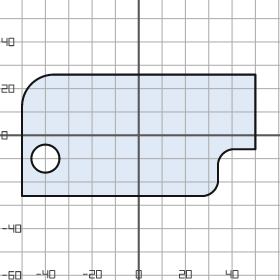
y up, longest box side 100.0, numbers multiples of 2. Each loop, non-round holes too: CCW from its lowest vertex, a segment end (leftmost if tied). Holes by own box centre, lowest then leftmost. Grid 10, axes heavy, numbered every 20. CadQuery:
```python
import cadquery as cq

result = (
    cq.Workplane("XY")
    .moveTo(-50.0, -26.0)
    .lineTo(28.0, -26.0)
    .threePointArc((32.0, -24.0), (34.0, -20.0))
    .lineTo(34.0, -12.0)
    .threePointArc((36.0, -8.0), (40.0, -6.0))
    .lineTo(50.0, -6.0)
    .lineTo(50.0, 26.0)
    .lineTo(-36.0, 26.0)
    .threePointArc((-46.0, 22.0), (-50.0, 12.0))
    .close()
    .moveTo(-40.0, -10.0)
    .circle(6.0)
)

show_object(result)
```